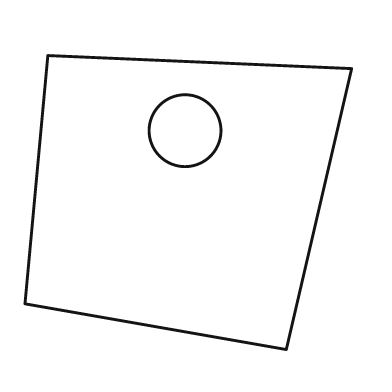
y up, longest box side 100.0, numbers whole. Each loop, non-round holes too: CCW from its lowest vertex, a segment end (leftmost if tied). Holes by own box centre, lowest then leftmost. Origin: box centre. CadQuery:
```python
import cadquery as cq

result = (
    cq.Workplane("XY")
    .moveTo(30.0, -45.0)
    .lineTo(50.0, 41.0)
    .lineTo(-43.0, 45.0)
    .lineTo(-50.0, -31.0)
    .close()
    .moveTo(-1.0, 22.0)
    .circle(11.0)
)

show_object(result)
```